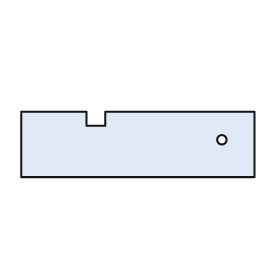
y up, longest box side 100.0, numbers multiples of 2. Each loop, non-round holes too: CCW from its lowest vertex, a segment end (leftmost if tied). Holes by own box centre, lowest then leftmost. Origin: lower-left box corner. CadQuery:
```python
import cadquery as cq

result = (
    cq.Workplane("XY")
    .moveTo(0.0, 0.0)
    .lineTo(100.0, 0.0)
    .lineTo(100.0, 28.0)
    .lineTo(36.0, 28.0)
    .lineTo(36.0, 22.0)
    .lineTo(28.0, 22.0)
    .lineTo(28.0, 28.0)
    .lineTo(0.0, 28.0)
    .close()
    .moveTo(86.0, 16.0)
    .circle(2.0)
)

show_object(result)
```